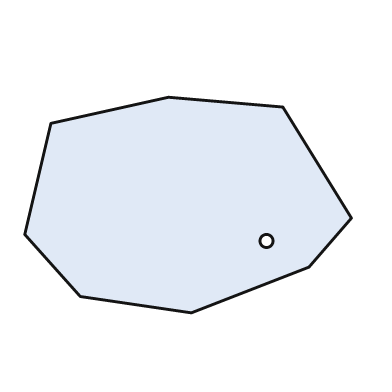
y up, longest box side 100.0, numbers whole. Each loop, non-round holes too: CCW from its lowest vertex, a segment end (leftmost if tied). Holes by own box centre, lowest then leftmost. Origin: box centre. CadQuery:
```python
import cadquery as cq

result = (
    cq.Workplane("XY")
    .moveTo(1.0, -33.0)
    .lineTo(37.0, -19.0)
    .lineTo(50.0, -4.0)
    .lineTo(29.0, 30.0)
    .lineTo(-6.0, 33.0)
    .lineTo(-42.0, 25.0)
    .lineTo(-50.0, -9.0)
    .lineTo(-33.0, -28.0)
    .close()
    .moveTo(24.0, -11.0)
    .circle(2.0)
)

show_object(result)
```